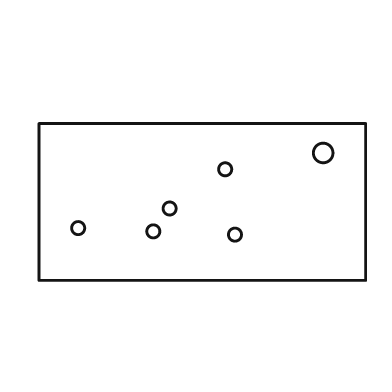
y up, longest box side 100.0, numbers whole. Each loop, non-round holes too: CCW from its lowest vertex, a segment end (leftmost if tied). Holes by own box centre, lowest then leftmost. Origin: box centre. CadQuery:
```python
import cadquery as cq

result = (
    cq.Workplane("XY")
    .moveTo(-50.0, -24.0)
    .lineTo(50.0, -24.0)
    .lineTo(50.0, 24.0)
    .lineTo(-50.0, 24.0)
    .close()
    .moveTo(10.0, -10.0)
    .circle(2.0)
    .moveTo(-15.0, -9.0)
    .circle(2.0)
    .moveTo(-38.0, -8.0)
    .circle(2.0)
    .moveTo(-10.0, -2.0)
    .circle(2.0)
    .moveTo(7.0, 10.0)
    .circle(2.0)
    .moveTo(37.0, 15.0)
    .circle(3.0)
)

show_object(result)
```